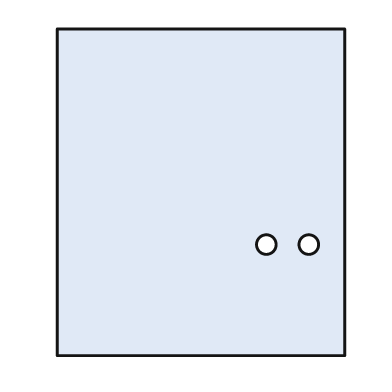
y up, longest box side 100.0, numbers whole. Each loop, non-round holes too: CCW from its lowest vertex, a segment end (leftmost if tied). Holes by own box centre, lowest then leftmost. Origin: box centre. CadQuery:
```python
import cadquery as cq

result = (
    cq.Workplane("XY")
    .moveTo(-44.0, -50.0)
    .lineTo(44.0, -50.0)
    .lineTo(44.0, 50.0)
    .lineTo(-44.0, 50.0)
    .close()
    .moveTo(20.0, -16.0)
    .circle(3.0)
    .moveTo(33.0, -16.0)
    .circle(3.0)
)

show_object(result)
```